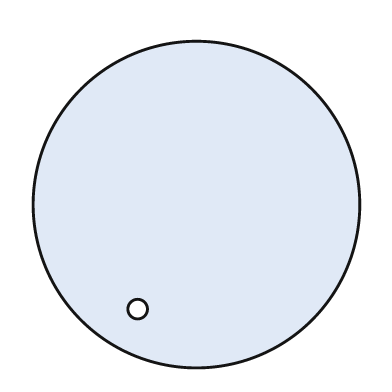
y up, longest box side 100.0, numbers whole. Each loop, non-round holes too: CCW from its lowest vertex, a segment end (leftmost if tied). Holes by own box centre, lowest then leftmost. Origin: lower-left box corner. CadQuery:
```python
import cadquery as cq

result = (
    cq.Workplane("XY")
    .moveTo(50.0, 50.0)
    .circle(50.0)
    .moveTo(32.0, 18.0)
    .circle(3.0)
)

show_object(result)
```